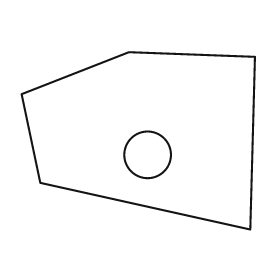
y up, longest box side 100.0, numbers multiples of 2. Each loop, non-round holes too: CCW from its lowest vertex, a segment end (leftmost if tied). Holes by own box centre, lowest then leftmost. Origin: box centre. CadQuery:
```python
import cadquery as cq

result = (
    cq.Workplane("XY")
    .moveTo(48.0, -38.0)
    .lineTo(50.0, 36.0)
    .lineTo(-4.0, 38.0)
    .lineTo(-50.0, 20.0)
    .lineTo(-42.0, -18.0)
    .close()
    .moveTo(4.0, -6.0)
    .circle(10.0)
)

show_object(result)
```